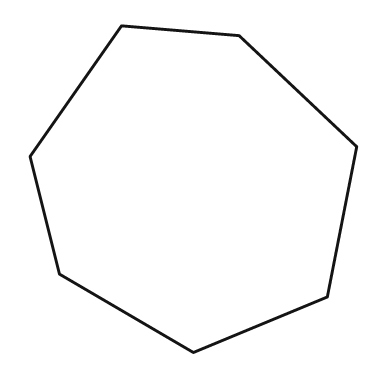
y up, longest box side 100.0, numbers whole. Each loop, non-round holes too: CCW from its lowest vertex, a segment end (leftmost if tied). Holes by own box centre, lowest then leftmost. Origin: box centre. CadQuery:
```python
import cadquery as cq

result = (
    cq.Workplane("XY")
    .moveTo(0.0, -50.0)
    .lineTo(41.0, -33.0)
    .lineTo(50.0, 13.0)
    .lineTo(14.0, 47.0)
    .lineTo(-22.0, 50.0)
    .lineTo(-50.0, 10.0)
    .lineTo(-41.0, -26.0)
    .close()
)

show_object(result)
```